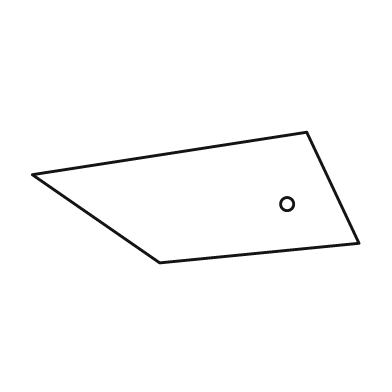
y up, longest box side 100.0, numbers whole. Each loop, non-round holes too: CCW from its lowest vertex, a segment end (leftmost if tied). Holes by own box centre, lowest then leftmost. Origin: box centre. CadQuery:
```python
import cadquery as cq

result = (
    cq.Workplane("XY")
    .moveTo(-11.0, -20.0)
    .lineTo(50.0, -14.0)
    .lineTo(34.0, 20.0)
    .lineTo(-50.0, 7.0)
    .close()
    .moveTo(28.0, -2.0)
    .circle(2.0)
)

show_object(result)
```